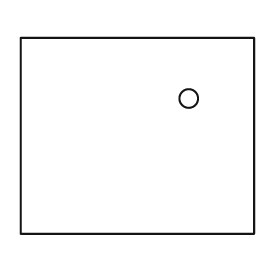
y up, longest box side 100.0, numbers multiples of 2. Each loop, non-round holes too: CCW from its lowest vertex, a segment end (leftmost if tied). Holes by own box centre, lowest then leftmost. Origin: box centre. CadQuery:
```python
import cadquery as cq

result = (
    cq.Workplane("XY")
    .moveTo(-50.0, -42.0)
    .lineTo(50.0, -42.0)
    .lineTo(50.0, 42.0)
    .lineTo(-50.0, 42.0)
    .close()
    .moveTo(22.0, 16.0)
    .circle(4.0)
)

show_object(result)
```